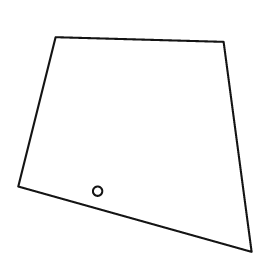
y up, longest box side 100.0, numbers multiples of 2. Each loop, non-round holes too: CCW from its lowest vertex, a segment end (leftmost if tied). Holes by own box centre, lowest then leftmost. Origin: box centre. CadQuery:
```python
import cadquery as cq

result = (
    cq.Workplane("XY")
    .moveTo(50.0, -46.0)
    .lineTo(38.0, 44.0)
    .lineTo(-34.0, 46.0)
    .lineTo(-50.0, -18.0)
    .close()
    .moveTo(-16.0, -20.0)
    .circle(2.0)
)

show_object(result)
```